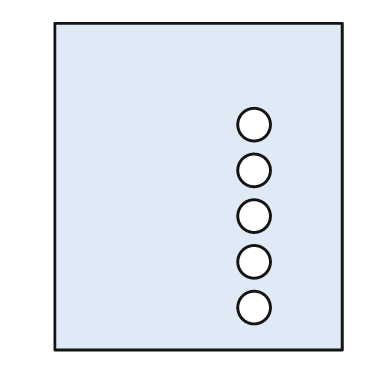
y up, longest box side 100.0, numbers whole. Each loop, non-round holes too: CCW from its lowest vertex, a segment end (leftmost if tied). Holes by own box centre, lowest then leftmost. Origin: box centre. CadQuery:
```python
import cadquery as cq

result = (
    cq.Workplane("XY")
    .moveTo(-44.0, -50.0)
    .lineTo(44.0, -50.0)
    .lineTo(44.0, 50.0)
    .lineTo(-44.0, 50.0)
    .close()
    .moveTo(17.0, -37.0)
    .circle(5.0)
    .moveTo(17.0, -23.0)
    .circle(5.0)
    .moveTo(17.0, -9.0)
    .circle(5.0)
    .moveTo(17.0, 5.0)
    .circle(5.0)
    .moveTo(17.0, 19.0)
    .circle(5.0)
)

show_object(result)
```